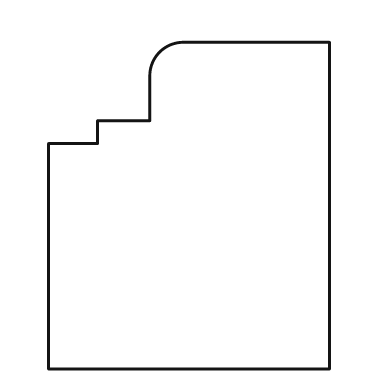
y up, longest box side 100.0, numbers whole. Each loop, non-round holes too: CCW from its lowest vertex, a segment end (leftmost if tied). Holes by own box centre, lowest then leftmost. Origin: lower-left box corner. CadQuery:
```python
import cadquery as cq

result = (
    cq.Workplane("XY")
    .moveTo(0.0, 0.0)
    .lineTo(86.0, 0.0)
    .lineTo(86.0, 100.0)
    .lineTo(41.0, 100.0)
    .threePointArc((34.0, 97.0), (31.0, 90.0))
    .lineTo(31.0, 76.0)
    .lineTo(15.0, 76.0)
    .lineTo(15.0, 69.0)
    .lineTo(0.0, 69.0)
    .close()
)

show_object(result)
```